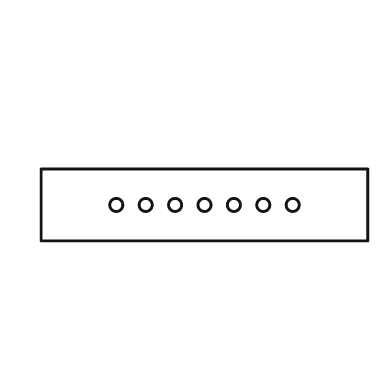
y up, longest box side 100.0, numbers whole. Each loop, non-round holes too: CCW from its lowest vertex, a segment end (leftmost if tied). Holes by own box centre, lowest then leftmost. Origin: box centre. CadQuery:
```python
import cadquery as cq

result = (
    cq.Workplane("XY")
    .moveTo(-50.0, -11.0)
    .lineTo(50.0, -11.0)
    .lineTo(50.0, 11.0)
    .lineTo(-50.0, 11.0)
    .close()
    .moveTo(-27.0, 0.0)
    .circle(2.0)
    .moveTo(-18.0, 0.0)
    .circle(2.0)
    .moveTo(-9.0, 0.0)
    .circle(2.0)
    .moveTo(0.0, 0.0)
    .circle(2.0)
    .moveTo(9.0, 0.0)
    .circle(2.0)
    .moveTo(18.0, 0.0)
    .circle(2.0)
    .moveTo(27.0, 0.0)
    .circle(2.0)
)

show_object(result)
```